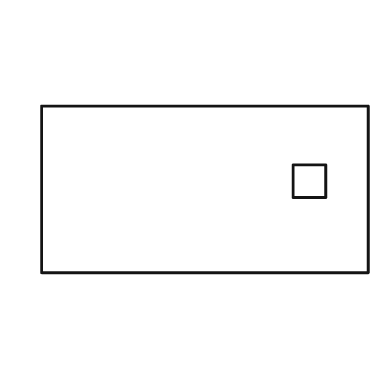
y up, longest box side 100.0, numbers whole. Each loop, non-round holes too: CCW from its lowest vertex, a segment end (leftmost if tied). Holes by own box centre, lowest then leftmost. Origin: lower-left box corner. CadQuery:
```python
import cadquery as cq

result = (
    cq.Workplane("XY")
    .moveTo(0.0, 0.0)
    .lineTo(100.0, 0.0)
    .lineTo(100.0, 51.0)
    .lineTo(0.0, 51.0)
    .close()
    .moveTo(77.0, 23.0)
    .lineTo(87.0, 23.0)
    .lineTo(87.0, 33.0)
    .lineTo(77.0, 33.0)
    .close()
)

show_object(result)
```